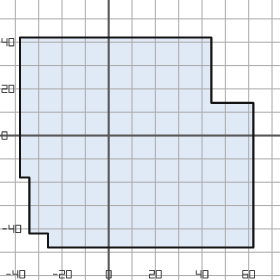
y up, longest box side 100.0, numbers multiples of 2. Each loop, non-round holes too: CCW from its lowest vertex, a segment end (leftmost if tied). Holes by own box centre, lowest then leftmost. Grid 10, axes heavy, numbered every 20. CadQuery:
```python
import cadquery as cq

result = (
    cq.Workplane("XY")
    .moveTo(-26.0, -48.0)
    .lineTo(62.0, -48.0)
    .lineTo(62.0, 14.0)
    .lineTo(44.0, 14.0)
    .lineTo(44.0, 42.0)
    .lineTo(-38.0, 42.0)
    .lineTo(-38.0, -18.0)
    .lineTo(-34.0, -18.0)
    .lineTo(-34.0, -42.0)
    .lineTo(-26.0, -42.0)
    .close()
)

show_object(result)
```